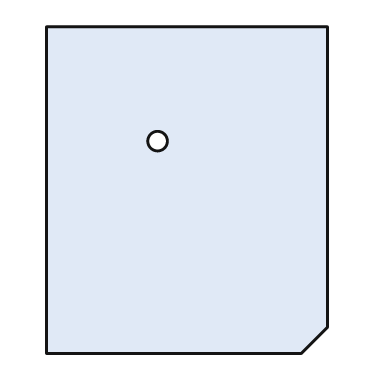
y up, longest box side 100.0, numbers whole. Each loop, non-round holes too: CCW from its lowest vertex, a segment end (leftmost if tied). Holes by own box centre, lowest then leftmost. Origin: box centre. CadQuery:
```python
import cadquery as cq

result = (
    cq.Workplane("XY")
    .moveTo(-43.0, -50.0)
    .lineTo(35.0, -50.0)
    .lineTo(43.0, -42.0)
    .lineTo(43.0, 50.0)
    .lineTo(-43.0, 50.0)
    .close()
    .moveTo(-9.0, 15.0)
    .circle(3.0)
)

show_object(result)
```